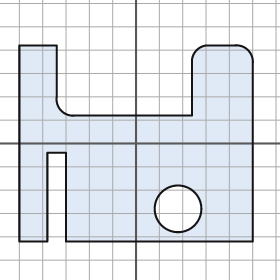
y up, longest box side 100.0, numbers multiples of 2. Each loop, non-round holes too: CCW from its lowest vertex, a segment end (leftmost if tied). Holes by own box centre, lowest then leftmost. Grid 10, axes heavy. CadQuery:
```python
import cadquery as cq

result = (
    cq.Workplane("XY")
    .moveTo(-50.0, -42.0)
    .lineTo(-38.0, -42.0)
    .lineTo(-38.0, -4.0)
    .lineTo(-30.0, -4.0)
    .lineTo(-30.0, -42.0)
    .lineTo(50.0, -42.0)
    .lineTo(50.0, 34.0)
    .threePointArc((48.0, 40.0), (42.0, 42.0))
    .lineTo(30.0, 42.0)
    .threePointArc((26.0, 40.0), (24.0, 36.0))
    .lineTo(24.0, 12.0)
    .lineTo(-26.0, 12.0)
    .threePointArc((-32.0, 14.0), (-34.0, 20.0))
    .lineTo(-34.0, 42.0)
    .lineTo(-50.0, 42.0)
    .close()
    .moveTo(18.0, -28.0)
    .circle(10.0)
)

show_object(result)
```